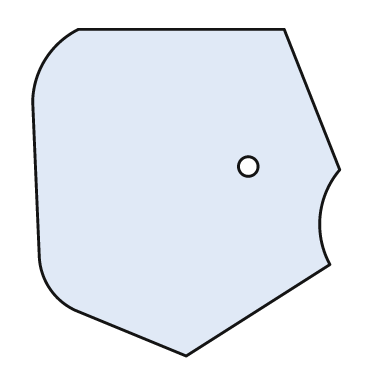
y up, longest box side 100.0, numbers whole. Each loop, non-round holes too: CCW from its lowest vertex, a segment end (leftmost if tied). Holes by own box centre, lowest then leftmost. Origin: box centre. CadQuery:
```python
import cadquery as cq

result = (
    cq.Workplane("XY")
    .moveTo(0.0, -50.0)
    .lineTo(44.0, -22.0)
    .threePointArc((41.0, -7.0), (47.0, 7.0))
    .lineTo(30.0, 50.0)
    .lineTo(-33.0, 50.0)
    .threePointArc((-43.0, 41.0), (-47.0, 28.0))
    .lineTo(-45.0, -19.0)
    .threePointArc((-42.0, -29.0), (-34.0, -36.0))
    .close()
    .moveTo(19.0, 8.0)
    .circle(3.0)
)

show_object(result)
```